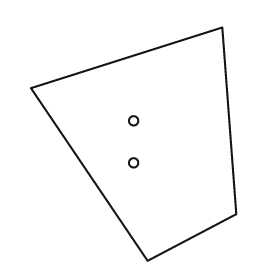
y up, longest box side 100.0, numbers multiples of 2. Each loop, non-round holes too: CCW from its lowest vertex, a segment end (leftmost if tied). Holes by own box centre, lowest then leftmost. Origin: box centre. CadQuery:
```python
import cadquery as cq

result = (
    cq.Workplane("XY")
    .moveTo(6.0, -50.0)
    .lineTo(44.0, -30.0)
    .lineTo(38.0, 50.0)
    .lineTo(-44.0, 24.0)
    .close()
    .moveTo(0.0, -8.0)
    .circle(2.0)
    .moveTo(0.0, 10.0)
    .circle(2.0)
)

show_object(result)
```